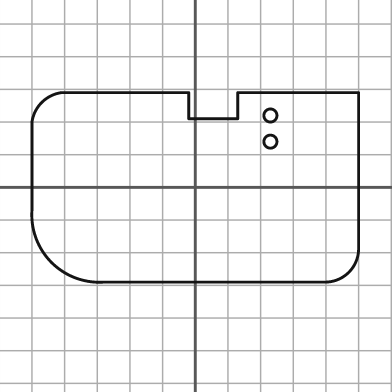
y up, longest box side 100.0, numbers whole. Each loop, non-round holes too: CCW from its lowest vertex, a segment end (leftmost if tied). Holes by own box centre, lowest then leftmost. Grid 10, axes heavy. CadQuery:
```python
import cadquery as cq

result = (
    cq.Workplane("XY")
    .moveTo(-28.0, -29.0)
    .lineTo(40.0, -29.0)
    .threePointArc((47.0, -26.0), (50.0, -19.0))
    .lineTo(50.0, 29.0)
    .lineTo(13.0, 29.0)
    .lineTo(13.0, 21.0)
    .lineTo(-2.0, 21.0)
    .lineTo(-2.0, 29.0)
    .lineTo(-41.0, 29.0)
    .threePointArc((-47.0, 26.0), (-50.0, 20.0))
    .lineTo(-50.0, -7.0)
    .threePointArc((-44.0, -23.0), (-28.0, -29.0))
    .close()
    .moveTo(23.0, 14.0)
    .circle(2.0)
    .moveTo(23.0, 22.0)
    .circle(2.0)
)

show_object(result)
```